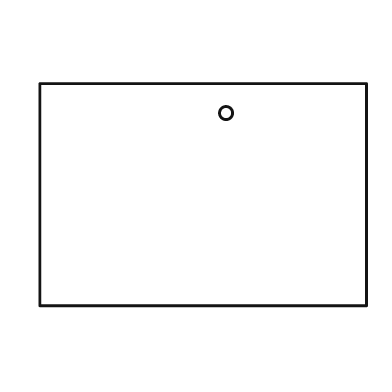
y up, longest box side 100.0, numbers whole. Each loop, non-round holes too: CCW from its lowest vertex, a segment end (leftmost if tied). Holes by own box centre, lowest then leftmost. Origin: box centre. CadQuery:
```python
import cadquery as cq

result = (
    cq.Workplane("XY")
    .moveTo(-50.0, -34.0)
    .lineTo(50.0, -34.0)
    .lineTo(50.0, 34.0)
    .lineTo(-50.0, 34.0)
    .close()
    .moveTo(7.0, 25.0)
    .circle(2.0)
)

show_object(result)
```